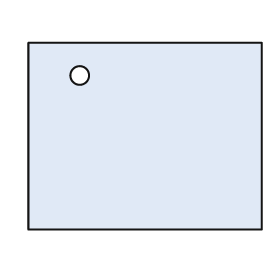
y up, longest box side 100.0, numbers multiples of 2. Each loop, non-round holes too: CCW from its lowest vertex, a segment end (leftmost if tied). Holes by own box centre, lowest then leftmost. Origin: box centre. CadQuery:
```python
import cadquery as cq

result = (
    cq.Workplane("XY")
    .moveTo(-50.0, -40.0)
    .lineTo(50.0, -40.0)
    .lineTo(50.0, 40.0)
    .lineTo(-50.0, 40.0)
    .close()
    .moveTo(-28.0, 26.0)
    .circle(4.0)
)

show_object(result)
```